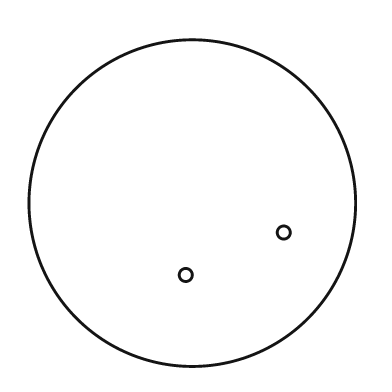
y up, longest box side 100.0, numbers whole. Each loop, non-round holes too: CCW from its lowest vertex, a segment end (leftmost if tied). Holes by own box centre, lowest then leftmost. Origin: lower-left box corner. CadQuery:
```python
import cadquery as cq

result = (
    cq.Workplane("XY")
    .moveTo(50.0, 50.0)
    .circle(50.0)
    .moveTo(48.0, 28.0)
    .circle(2.0)
    .moveTo(78.0, 41.0)
    .circle(2.0)
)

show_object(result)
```